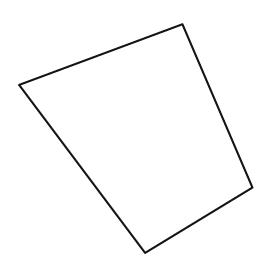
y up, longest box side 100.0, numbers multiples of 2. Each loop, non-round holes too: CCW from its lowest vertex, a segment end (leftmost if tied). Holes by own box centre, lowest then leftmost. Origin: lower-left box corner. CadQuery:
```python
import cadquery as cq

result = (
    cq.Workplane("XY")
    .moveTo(54.0, 0.0)
    .lineTo(100.0, 28.0)
    .lineTo(70.0, 98.0)
    .lineTo(0.0, 72.0)
    .close()
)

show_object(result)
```